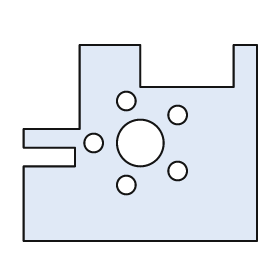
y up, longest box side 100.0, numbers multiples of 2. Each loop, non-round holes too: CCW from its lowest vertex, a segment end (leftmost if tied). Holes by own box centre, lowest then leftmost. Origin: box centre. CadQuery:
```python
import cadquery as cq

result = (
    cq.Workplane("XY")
    .moveTo(-50.0, -42.0)
    .lineTo(50.0, -42.0)
    .lineTo(50.0, 42.0)
    .lineTo(40.0, 42.0)
    .lineTo(40.0, 24.0)
    .lineTo(0.0, 24.0)
    .lineTo(0.0, 42.0)
    .lineTo(-26.0, 42.0)
    .lineTo(-26.0, 6.0)
    .lineTo(-50.0, 6.0)
    .lineTo(-50.0, -2.0)
    .lineTo(-28.0, -2.0)
    .lineTo(-28.0, -10.0)
    .lineTo(-50.0, -10.0)
    .close()
    .moveTo(-6.0, -18.0)
    .circle(4.0)
    .moveTo(16.0, -12.0)
    .circle(4.0)
    .moveTo(-20.0, 0.0)
    .circle(4.0)
    .moveTo(0.0, 0.0)
    .circle(10.0)
    .moveTo(16.0, 12.0)
    .circle(4.0)
    .moveTo(-6.0, 18.0)
    .circle(4.0)
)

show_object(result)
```